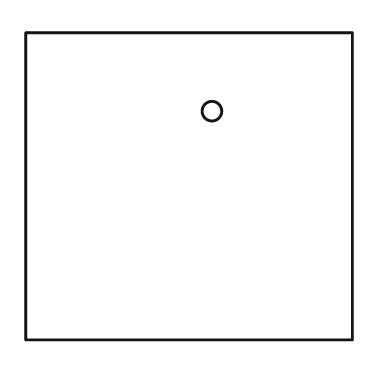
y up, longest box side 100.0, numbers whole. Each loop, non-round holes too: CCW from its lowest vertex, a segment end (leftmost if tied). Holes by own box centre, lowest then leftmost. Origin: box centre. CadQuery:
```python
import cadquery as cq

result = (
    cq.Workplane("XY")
    .moveTo(-50.0, -47.0)
    .lineTo(50.0, -47.0)
    .lineTo(50.0, 47.0)
    .lineTo(-50.0, 47.0)
    .close()
    .moveTo(7.0, 23.0)
    .circle(3.0)
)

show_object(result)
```